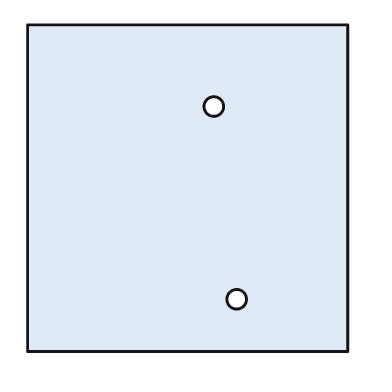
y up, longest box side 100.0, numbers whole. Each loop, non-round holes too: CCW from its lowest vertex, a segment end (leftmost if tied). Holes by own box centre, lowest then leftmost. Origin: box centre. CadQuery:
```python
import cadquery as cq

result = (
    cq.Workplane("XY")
    .moveTo(-49.0, -50.0)
    .lineTo(49.0, -50.0)
    .lineTo(49.0, 50.0)
    .lineTo(-49.0, 50.0)
    .close()
    .moveTo(15.0, -34.0)
    .circle(3.0)
    .moveTo(8.0, 25.0)
    .circle(3.0)
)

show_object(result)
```